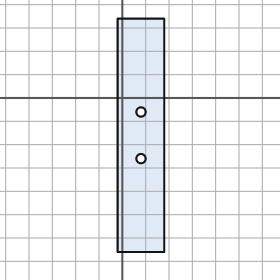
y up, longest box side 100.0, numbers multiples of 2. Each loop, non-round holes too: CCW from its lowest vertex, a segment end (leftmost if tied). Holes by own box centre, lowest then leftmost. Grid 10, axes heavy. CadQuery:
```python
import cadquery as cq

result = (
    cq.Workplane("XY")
    .moveTo(-2.0, -66.0)
    .lineTo(18.0, -66.0)
    .lineTo(18.0, 34.0)
    .lineTo(-2.0, 34.0)
    .close()
    .moveTo(8.0, -26.0)
    .circle(2.0)
    .moveTo(8.0, -6.0)
    .circle(2.0)
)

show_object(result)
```